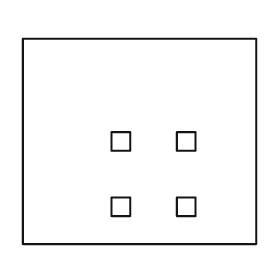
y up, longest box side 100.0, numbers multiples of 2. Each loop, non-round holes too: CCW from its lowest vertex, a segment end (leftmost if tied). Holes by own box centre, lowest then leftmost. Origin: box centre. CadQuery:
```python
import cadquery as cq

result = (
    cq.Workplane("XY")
    .moveTo(-50.0, -44.0)
    .lineTo(50.0, -44.0)
    .lineTo(50.0, 44.0)
    .lineTo(-50.0, 44.0)
    .close()
    .moveTo(-12.0, -32.0)
    .lineTo(-4.0, -32.0)
    .lineTo(-4.0, -24.0)
    .lineTo(-12.0, -24.0)
    .close()
    .moveTo(16.0, -32.0)
    .lineTo(24.0, -32.0)
    .lineTo(24.0, -24.0)
    .lineTo(16.0, -24.0)
    .close()
    .moveTo(-12.0, -4.0)
    .lineTo(-4.0, -4.0)
    .lineTo(-4.0, 4.0)
    .lineTo(-12.0, 4.0)
    .close()
    .moveTo(16.0, -4.0)
    .lineTo(24.0, -4.0)
    .lineTo(24.0, 4.0)
    .lineTo(16.0, 4.0)
    .close()
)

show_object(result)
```